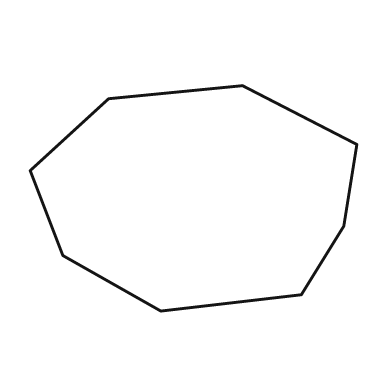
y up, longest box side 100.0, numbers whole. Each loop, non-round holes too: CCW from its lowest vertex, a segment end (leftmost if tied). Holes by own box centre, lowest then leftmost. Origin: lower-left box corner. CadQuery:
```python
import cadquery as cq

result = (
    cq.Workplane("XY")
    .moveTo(40.0, 0.0)
    .lineTo(83.0, 5.0)
    .lineTo(96.0, 26.0)
    .lineTo(100.0, 51.0)
    .lineTo(65.0, 69.0)
    .lineTo(24.0, 65.0)
    .lineTo(0.0, 43.0)
    .lineTo(10.0, 17.0)
    .close()
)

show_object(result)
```